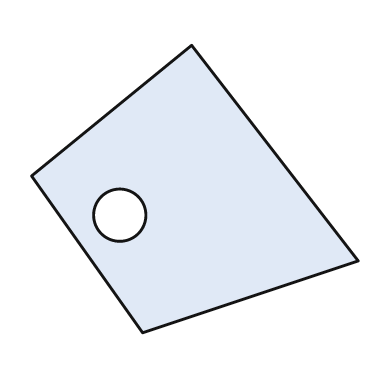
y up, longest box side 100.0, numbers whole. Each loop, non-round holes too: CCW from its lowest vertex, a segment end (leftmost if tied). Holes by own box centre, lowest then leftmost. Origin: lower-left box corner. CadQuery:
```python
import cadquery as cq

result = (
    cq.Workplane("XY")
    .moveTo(34.0, 0.0)
    .lineTo(100.0, 22.0)
    .lineTo(49.0, 88.0)
    .lineTo(0.0, 48.0)
    .close()
    .moveTo(27.0, 36.0)
    .circle(8.0)
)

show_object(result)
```